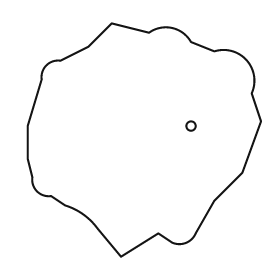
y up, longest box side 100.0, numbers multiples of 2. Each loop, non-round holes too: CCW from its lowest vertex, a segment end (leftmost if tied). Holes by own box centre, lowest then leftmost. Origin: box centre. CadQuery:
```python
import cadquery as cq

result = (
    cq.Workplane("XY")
    .moveTo(-10.0, -50.0)
    .lineTo(6.0, -40.0)
    .lineTo(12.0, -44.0)
    .threePointArc((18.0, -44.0), (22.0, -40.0))
    .lineTo(30.0, -26.0)
    .lineTo(42.0, -14.0)
    .lineTo(50.0, 8.0)
    .lineTo(46.0, 20.0)
    .threePointArc((44.0, 34.0), (30.0, 38.0))
    .lineTo(20.0, 42.0)
    .threePointArc((12.0, 48.0), (2.0, 46.0))
    .lineTo(-14.0, 50.0)
    .lineTo(-24.0, 40.0)
    .lineTo(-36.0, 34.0)
    .threePointArc((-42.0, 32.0), (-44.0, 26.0))
    .lineTo(-50.0, 6.0)
    .lineTo(-50.0, -8.0)
    .lineTo(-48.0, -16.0)
    .threePointArc((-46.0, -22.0), (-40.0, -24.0))
    .lineTo(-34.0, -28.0)
    .threePointArc((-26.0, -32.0), (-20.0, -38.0))
    .close()
    .moveTo(20.0, 6.0)
    .circle(2.0)
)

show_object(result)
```